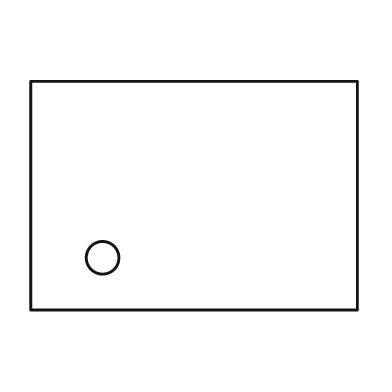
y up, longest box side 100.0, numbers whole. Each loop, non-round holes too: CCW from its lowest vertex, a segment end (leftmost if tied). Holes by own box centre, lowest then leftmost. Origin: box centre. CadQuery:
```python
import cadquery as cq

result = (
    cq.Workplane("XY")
    .moveTo(-50.0, -35.0)
    .lineTo(50.0, -35.0)
    .lineTo(50.0, 35.0)
    .lineTo(-50.0, 35.0)
    .close()
    .moveTo(-28.0, -19.0)
    .circle(5.0)
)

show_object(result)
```